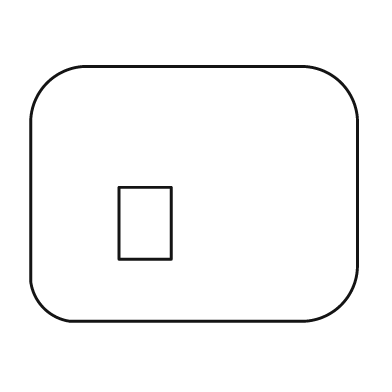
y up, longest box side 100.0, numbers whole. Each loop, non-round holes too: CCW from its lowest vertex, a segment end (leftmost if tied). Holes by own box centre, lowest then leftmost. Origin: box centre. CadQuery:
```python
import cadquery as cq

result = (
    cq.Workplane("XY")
    .moveTo(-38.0, -39.0)
    .lineTo(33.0, -39.0)
    .threePointArc((45.0, -34.0), (50.0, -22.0))
    .lineTo(50.0, 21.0)
    .threePointArc((45.0, 34.0), (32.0, 39.0))
    .lineTo(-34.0, 39.0)
    .threePointArc((-45.0, 34.0), (-50.0, 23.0))
    .lineTo(-50.0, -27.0)
    .threePointArc((-46.0, -35.0), (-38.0, -39.0))
    .close()
    .moveTo(-23.0, -20.0)
    .lineTo(-7.0, -20.0)
    .lineTo(-7.0, 2.0)
    .lineTo(-23.0, 2.0)
    .close()
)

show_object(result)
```